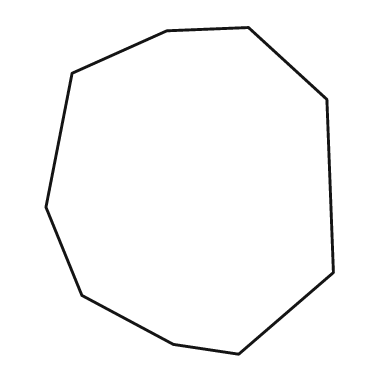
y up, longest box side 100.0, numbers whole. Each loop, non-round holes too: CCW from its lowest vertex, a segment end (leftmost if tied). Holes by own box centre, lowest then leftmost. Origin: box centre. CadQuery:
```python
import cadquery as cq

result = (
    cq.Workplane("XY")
    .moveTo(15.0, -50.0)
    .lineTo(44.0, -25.0)
    .lineTo(42.0, 28.0)
    .lineTo(18.0, 50.0)
    .lineTo(-7.0, 49.0)
    .lineTo(-36.0, 36.0)
    .lineTo(-44.0, -5.0)
    .lineTo(-33.0, -32.0)
    .lineTo(-5.0, -47.0)
    .close()
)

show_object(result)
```